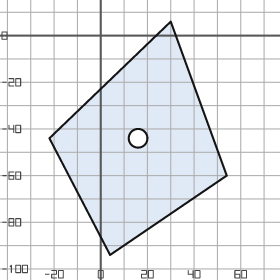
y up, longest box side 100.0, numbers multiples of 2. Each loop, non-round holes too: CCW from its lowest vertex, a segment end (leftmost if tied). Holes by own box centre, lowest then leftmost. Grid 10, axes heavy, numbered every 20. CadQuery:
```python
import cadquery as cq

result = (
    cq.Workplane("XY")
    .moveTo(4.0, -94.0)
    .lineTo(54.0, -60.0)
    .lineTo(30.0, 6.0)
    .lineTo(-22.0, -44.0)
    .close()
    .moveTo(16.0, -44.0)
    .circle(4.0)
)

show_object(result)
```